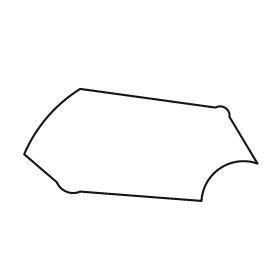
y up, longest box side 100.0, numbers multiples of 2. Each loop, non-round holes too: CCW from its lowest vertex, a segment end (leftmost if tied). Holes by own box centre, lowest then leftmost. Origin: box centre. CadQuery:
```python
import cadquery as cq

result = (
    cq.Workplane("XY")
    .moveTo(26.0, -24.0)
    .threePointArc((34.0, -10.0), (50.0, -8.0))
    .lineTo(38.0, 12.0)
    .threePointArc((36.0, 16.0), (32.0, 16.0))
    .lineTo(-26.0, 24.0)
    .threePointArc((-40.0, 12.0), (-50.0, -4.0))
    .lineTo(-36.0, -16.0)
    .threePointArc((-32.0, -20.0), (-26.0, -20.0))
    .close()
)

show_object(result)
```